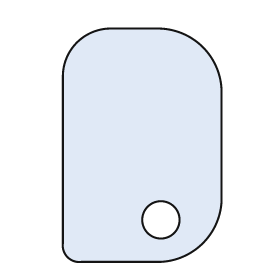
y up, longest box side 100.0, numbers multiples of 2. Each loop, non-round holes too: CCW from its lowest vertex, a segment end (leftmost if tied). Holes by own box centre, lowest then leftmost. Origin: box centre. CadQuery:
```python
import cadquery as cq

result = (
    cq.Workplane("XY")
    .moveTo(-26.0, -50.0)
    .lineTo(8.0, -50.0)
    .threePointArc((26.0, -42.0), (34.0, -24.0))
    .lineTo(34.0, 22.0)
    .threePointArc((26.0, 42.0), (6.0, 50.0))
    .lineTo(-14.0, 50.0)
    .threePointArc((-28.0, 44.0), (-34.0, 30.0))
    .lineTo(-34.0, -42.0)
    .threePointArc((-32.0, -48.0), (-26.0, -50.0))
    .close()
    .moveTo(8.0, -32.0)
    .circle(8.0)
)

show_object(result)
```